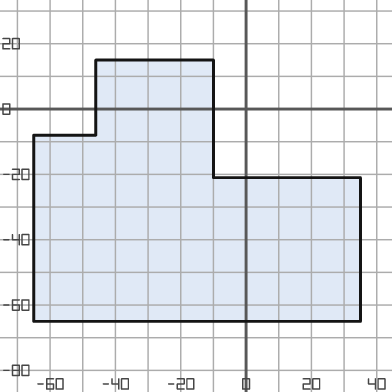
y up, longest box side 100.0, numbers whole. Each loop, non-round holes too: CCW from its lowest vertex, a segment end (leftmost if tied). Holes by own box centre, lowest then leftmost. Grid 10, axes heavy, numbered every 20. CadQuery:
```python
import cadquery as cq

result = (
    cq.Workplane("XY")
    .moveTo(-65.0, -65.0)
    .lineTo(35.0, -65.0)
    .lineTo(35.0, -21.0)
    .lineTo(-10.0, -21.0)
    .lineTo(-10.0, 15.0)
    .lineTo(-46.0, 15.0)
    .lineTo(-46.0, -8.0)
    .lineTo(-65.0, -8.0)
    .close()
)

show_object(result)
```